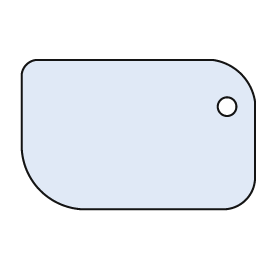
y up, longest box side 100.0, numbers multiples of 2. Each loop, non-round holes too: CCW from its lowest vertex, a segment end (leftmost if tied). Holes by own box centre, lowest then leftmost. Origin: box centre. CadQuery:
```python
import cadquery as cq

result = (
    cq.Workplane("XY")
    .moveTo(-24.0, -32.0)
    .lineTo(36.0, -32.0)
    .threePointArc((46.0, -28.0), (50.0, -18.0))
    .lineTo(50.0, 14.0)
    .threePointArc((44.0, 26.0), (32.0, 32.0))
    .lineTo(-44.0, 32.0)
    .threePointArc((-48.0, 30.0), (-50.0, 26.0))
    .lineTo(-50.0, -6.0)
    .threePointArc((-42.0, -24.0), (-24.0, -32.0))
    .close()
    .moveTo(38.0, 12.0)
    .circle(4.0)
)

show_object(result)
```